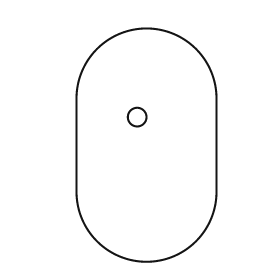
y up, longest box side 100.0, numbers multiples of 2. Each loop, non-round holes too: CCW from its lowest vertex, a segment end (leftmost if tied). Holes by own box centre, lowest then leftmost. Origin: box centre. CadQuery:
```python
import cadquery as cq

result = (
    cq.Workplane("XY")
    .moveTo(-30.0, -20.0)
    .threePointArc((0.0, -50.0), (30.0, -20.0))
    .lineTo(30.0, 20.0)
    .threePointArc((0.0, 50.0), (-30.0, 20.0))
    .close()
    .moveTo(-4.0, 12.0)
    .circle(4.0)
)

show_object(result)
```